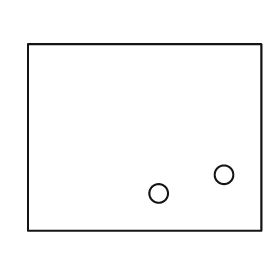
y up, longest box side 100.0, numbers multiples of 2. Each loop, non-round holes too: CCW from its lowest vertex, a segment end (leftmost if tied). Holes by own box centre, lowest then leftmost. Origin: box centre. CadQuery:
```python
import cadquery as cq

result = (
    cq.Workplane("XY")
    .moveTo(-50.0, -40.0)
    .lineTo(50.0, -40.0)
    .lineTo(50.0, 40.0)
    .lineTo(-50.0, 40.0)
    .close()
    .moveTo(6.0, -24.0)
    .circle(4.0)
    .moveTo(34.0, -16.0)
    .circle(4.0)
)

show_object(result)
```